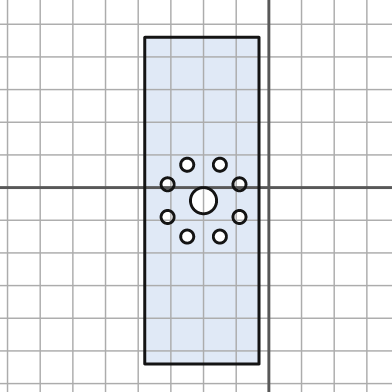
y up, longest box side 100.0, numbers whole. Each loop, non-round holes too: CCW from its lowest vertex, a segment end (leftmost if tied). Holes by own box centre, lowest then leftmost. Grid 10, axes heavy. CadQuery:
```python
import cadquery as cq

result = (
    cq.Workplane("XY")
    .moveTo(-38.0, -54.0)
    .lineTo(-3.0, -54.0)
    .lineTo(-3.0, 46.0)
    .lineTo(-38.0, 46.0)
    .close()
    .moveTo(-25.0, -15.0)
    .circle(2.0)
    .moveTo(-15.0, -15.0)
    .circle(2.0)
    .moveTo(-31.0, -9.0)
    .circle(2.0)
    .moveTo(-9.0, -9.0)
    .circle(2.0)
    .moveTo(-20.0, -4.0)
    .circle(4.0)
    .moveTo(-31.0, 1.0)
    .circle(2.0)
    .moveTo(-9.0, 1.0)
    .circle(2.0)
    .moveTo(-25.0, 7.0)
    .circle(2.0)
    .moveTo(-15.0, 7.0)
    .circle(2.0)
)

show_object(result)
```